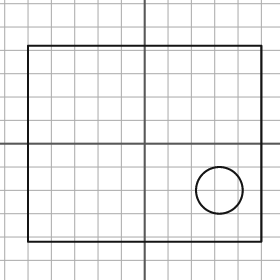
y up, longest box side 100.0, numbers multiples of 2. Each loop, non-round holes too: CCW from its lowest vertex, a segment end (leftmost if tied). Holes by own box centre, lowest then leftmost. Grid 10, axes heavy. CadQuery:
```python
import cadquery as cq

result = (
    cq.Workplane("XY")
    .moveTo(-50.0, -42.0)
    .lineTo(50.0, -42.0)
    .lineTo(50.0, 42.0)
    .lineTo(-50.0, 42.0)
    .close()
    .moveTo(32.0, -20.0)
    .circle(10.0)
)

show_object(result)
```